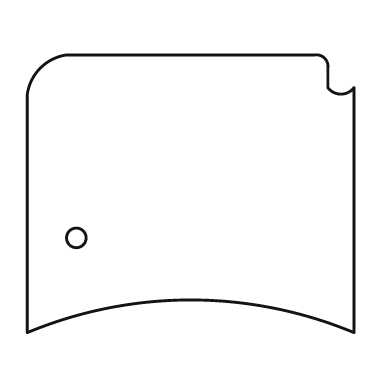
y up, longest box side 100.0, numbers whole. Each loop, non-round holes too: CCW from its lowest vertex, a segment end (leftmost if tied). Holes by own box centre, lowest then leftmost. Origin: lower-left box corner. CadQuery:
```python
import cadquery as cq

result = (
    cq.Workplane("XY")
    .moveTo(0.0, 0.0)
    .threePointArc((50.0, 10.0), (100.0, 0.0))
    .lineTo(100.0, 75.0)
    .threePointArc((96.0, 73.0), (92.0, 75.0))
    .lineTo(92.0, 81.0)
    .threePointArc((91.0, 84.0), (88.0, 85.0))
    .lineTo(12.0, 85.0)
    .threePointArc((4.0, 81.0), (0.0, 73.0))
    .close()
    .moveTo(15.0, 29.0)
    .circle(3.0)
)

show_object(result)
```